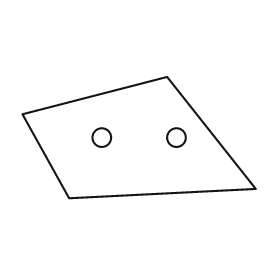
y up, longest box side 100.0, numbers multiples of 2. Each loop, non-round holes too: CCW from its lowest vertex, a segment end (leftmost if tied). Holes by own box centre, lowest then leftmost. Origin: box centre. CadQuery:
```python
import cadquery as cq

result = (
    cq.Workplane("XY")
    .moveTo(-30.0, -26.0)
    .lineTo(50.0, -22.0)
    .lineTo(12.0, 26.0)
    .lineTo(-50.0, 10.0)
    .close()
    .moveTo(-16.0, 0.0)
    .circle(4.0)
    .moveTo(16.0, 0.0)
    .circle(4.0)
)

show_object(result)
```